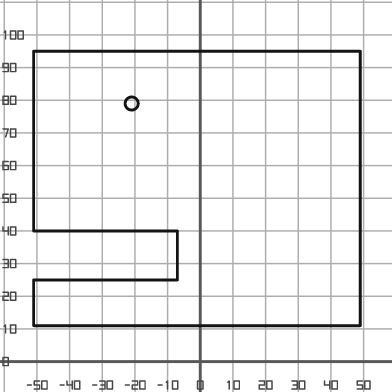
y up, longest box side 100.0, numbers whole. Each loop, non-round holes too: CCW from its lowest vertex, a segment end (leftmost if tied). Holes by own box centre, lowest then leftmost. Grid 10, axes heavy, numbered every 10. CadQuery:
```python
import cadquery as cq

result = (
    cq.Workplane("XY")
    .moveTo(-51.0, 11.0)
    .lineTo(49.0, 11.0)
    .lineTo(49.0, 95.0)
    .lineTo(-51.0, 95.0)
    .lineTo(-51.0, 40.0)
    .lineTo(-7.0, 40.0)
    .lineTo(-7.0, 25.0)
    .lineTo(-51.0, 25.0)
    .close()
    .moveTo(-21.0, 79.0)
    .circle(2.0)
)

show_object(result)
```